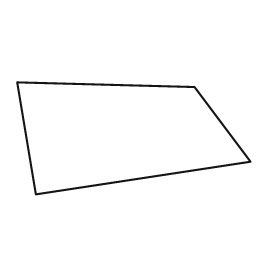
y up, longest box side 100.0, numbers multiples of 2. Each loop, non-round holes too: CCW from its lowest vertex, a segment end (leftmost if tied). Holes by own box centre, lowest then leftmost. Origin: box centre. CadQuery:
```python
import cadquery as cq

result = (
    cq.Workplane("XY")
    .moveTo(-42.0, -24.0)
    .lineTo(50.0, -10.0)
    .lineTo(26.0, 22.0)
    .lineTo(-50.0, 24.0)
    .close()
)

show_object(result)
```